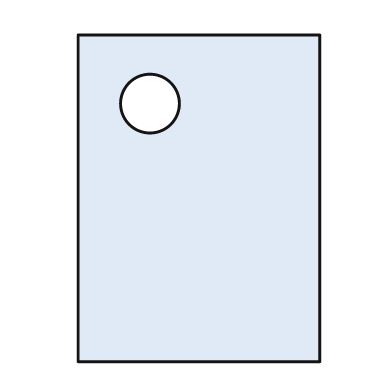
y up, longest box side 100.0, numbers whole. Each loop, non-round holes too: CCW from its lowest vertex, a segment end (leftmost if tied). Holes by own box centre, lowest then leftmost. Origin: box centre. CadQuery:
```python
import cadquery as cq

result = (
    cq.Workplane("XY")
    .moveTo(-37.0, -50.0)
    .lineTo(37.0, -50.0)
    .lineTo(37.0, 50.0)
    .lineTo(-37.0, 50.0)
    .close()
    .moveTo(-15.0, 29.0)
    .circle(9.0)
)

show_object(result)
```